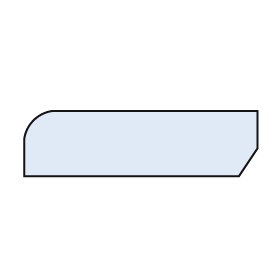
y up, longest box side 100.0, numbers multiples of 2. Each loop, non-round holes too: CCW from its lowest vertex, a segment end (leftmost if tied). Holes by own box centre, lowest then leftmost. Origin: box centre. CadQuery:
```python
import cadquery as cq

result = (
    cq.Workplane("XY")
    .moveTo(-50.0, -14.0)
    .lineTo(42.0, -14.0)
    .lineTo(50.0, -2.0)
    .lineTo(50.0, 14.0)
    .lineTo(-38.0, 14.0)
    .threePointArc((-46.0, 10.0), (-50.0, 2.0))
    .close()
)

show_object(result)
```